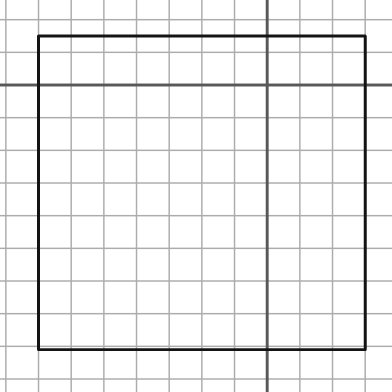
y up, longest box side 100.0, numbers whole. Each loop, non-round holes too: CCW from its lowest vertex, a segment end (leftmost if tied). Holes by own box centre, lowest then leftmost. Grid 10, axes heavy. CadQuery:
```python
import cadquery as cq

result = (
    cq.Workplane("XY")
    .moveTo(-70.0, -81.0)
    .lineTo(30.0, -81.0)
    .lineTo(30.0, 15.0)
    .lineTo(-70.0, 15.0)
    .close()
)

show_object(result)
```